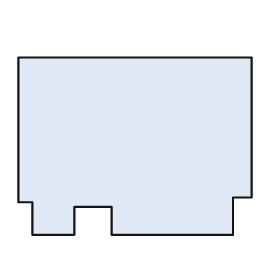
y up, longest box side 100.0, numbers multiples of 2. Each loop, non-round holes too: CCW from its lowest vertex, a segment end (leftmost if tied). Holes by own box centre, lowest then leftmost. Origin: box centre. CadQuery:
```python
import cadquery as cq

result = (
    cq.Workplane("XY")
    .moveTo(-44.0, -38.0)
    .lineTo(-26.0, -38.0)
    .lineTo(-26.0, -26.0)
    .lineTo(-10.0, -26.0)
    .lineTo(-10.0, -38.0)
    .lineTo(42.0, -38.0)
    .lineTo(42.0, -22.0)
    .lineTo(50.0, -22.0)
    .lineTo(50.0, 38.0)
    .lineTo(-50.0, 38.0)
    .lineTo(-50.0, -24.0)
    .lineTo(-44.0, -24.0)
    .close()
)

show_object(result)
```